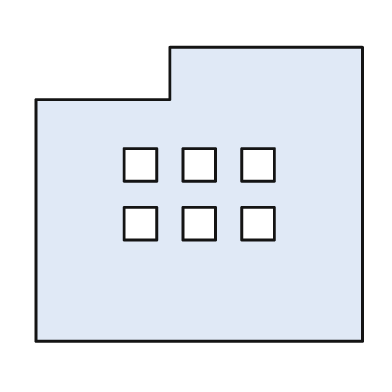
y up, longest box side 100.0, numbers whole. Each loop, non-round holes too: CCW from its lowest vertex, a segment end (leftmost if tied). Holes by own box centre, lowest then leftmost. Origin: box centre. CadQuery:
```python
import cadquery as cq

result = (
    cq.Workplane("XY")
    .moveTo(-50.0, -45.0)
    .lineTo(50.0, -45.0)
    .lineTo(50.0, 45.0)
    .lineTo(-9.0, 45.0)
    .lineTo(-9.0, 29.0)
    .lineTo(-50.0, 29.0)
    .close()
    .moveTo(-23.0, -14.0)
    .lineTo(-13.0, -14.0)
    .lineTo(-13.0, -4.0)
    .lineTo(-23.0, -4.0)
    .close()
    .moveTo(-5.0, -14.0)
    .lineTo(5.0, -14.0)
    .lineTo(5.0, -4.0)
    .lineTo(-5.0, -4.0)
    .close()
    .moveTo(13.0, -14.0)
    .lineTo(23.0, -14.0)
    .lineTo(23.0, -4.0)
    .lineTo(13.0, -4.0)
    .close()
    .moveTo(-23.0, 4.0)
    .lineTo(-13.0, 4.0)
    .lineTo(-13.0, 14.0)
    .lineTo(-23.0, 14.0)
    .close()
    .moveTo(-5.0, 4.0)
    .lineTo(5.0, 4.0)
    .lineTo(5.0, 14.0)
    .lineTo(-5.0, 14.0)
    .close()
    .moveTo(13.0, 4.0)
    .lineTo(23.0, 4.0)
    .lineTo(23.0, 14.0)
    .lineTo(13.0, 14.0)
    .close()
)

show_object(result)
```